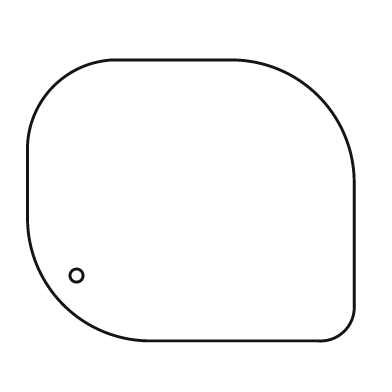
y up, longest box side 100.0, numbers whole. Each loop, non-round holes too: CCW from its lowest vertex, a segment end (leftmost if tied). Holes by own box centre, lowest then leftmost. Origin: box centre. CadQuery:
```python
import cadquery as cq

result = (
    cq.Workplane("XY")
    .moveTo(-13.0, -43.0)
    .lineTo(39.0, -43.0)
    .threePointArc((47.0, -40.0), (50.0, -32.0))
    .lineTo(50.0, 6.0)
    .threePointArc((39.0, 32.0), (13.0, 43.0))
    .lineTo(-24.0, 43.0)
    .threePointArc((-42.0, 35.0), (-50.0, 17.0))
    .lineTo(-50.0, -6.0)
    .threePointArc((-39.0, -32.0), (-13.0, -43.0))
    .close()
    .moveTo(-35.0, -23.0)
    .circle(2.0)
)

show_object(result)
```